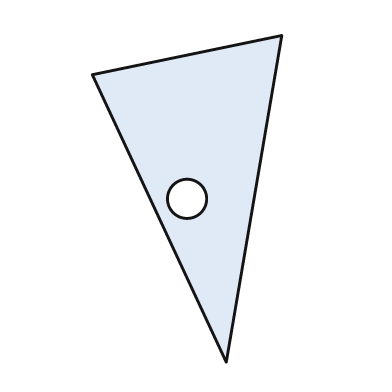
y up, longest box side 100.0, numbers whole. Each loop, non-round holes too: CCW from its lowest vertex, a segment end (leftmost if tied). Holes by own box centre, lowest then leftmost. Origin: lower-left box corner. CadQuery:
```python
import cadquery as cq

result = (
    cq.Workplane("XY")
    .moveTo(41.0, 0.0)
    .lineTo(58.0, 100.0)
    .lineTo(0.0, 88.0)
    .close()
    .moveTo(29.0, 50.0)
    .circle(6.0)
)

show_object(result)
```